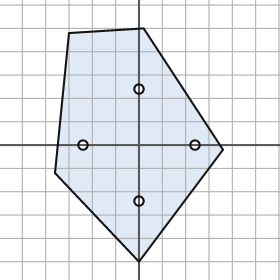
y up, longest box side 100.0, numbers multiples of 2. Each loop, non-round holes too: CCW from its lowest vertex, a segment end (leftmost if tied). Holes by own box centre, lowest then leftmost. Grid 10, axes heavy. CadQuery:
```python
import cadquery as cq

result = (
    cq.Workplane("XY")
    .moveTo(0.0, -50.0)
    .lineTo(36.0, -2.0)
    .lineTo(2.0, 50.0)
    .lineTo(-30.0, 48.0)
    .lineTo(-36.0, -12.0)
    .close()
    .moveTo(0.0, -24.0)
    .circle(2.0)
    .moveTo(-24.0, 0.0)
    .circle(2.0)
    .moveTo(24.0, 0.0)
    .circle(2.0)
    .moveTo(0.0, 24.0)
    .circle(2.0)
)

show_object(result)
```